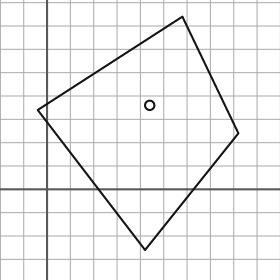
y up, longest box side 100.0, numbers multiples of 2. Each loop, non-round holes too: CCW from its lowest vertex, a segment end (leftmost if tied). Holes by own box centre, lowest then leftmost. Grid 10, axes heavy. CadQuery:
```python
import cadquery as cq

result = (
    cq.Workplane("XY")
    .moveTo(42.0, -26.0)
    .lineTo(82.0, 24.0)
    .lineTo(58.0, 74.0)
    .lineTo(-4.0, 34.0)
    .close()
    .moveTo(44.0, 36.0)
    .circle(2.0)
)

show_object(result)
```